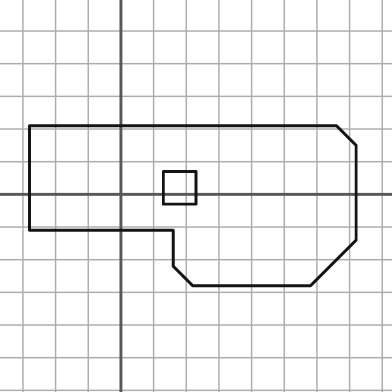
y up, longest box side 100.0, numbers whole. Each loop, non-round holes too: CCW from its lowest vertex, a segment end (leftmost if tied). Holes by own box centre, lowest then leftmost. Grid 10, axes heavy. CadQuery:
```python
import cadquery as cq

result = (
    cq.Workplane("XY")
    .moveTo(22.0, -28.0)
    .lineTo(58.0, -28.0)
    .lineTo(72.0, -14.0)
    .lineTo(72.0, 15.0)
    .lineTo(66.0, 21.0)
    .lineTo(-28.0, 21.0)
    .lineTo(-28.0, -11.0)
    .lineTo(16.0, -11.0)
    .lineTo(16.0, -22.0)
    .close()
    .moveTo(13.0, -3.0)
    .lineTo(23.0, -3.0)
    .lineTo(23.0, 7.0)
    .lineTo(13.0, 7.0)
    .close()
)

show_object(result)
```